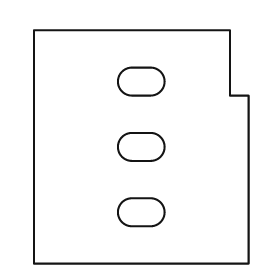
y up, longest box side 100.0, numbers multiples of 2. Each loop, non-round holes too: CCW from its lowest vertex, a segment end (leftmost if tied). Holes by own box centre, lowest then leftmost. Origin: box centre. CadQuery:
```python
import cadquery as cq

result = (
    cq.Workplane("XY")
    .moveTo(-46.0, -50.0)
    .lineTo(46.0, -50.0)
    .lineTo(46.0, 22.0)
    .lineTo(38.0, 22.0)
    .lineTo(38.0, 50.0)
    .lineTo(-46.0, 50.0)
    .close()
    .moveTo(-4.0, -34.0)
    .lineTo(4.0, -34.0)
    .threePointArc((10.0, -28.0), (4.0, -22.0))
    .lineTo(-4.0, -22.0)
    .threePointArc((-10.0, -28.0), (-4.0, -34.0))
    .close()
    .moveTo(-4.0, -6.0)
    .lineTo(4.0, -6.0)
    .threePointArc((10.0, 0.0), (4.0, 6.0))
    .lineTo(-4.0, 6.0)
    .threePointArc((-10.0, 0.0), (-4.0, -6.0))
    .close()
    .moveTo(-4.0, 22.0)
    .lineTo(4.0, 22.0)
    .threePointArc((10.0, 28.0), (4.0, 34.0))
    .lineTo(-4.0, 34.0)
    .threePointArc((-10.0, 28.0), (-4.0, 22.0))
    .close()
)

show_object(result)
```